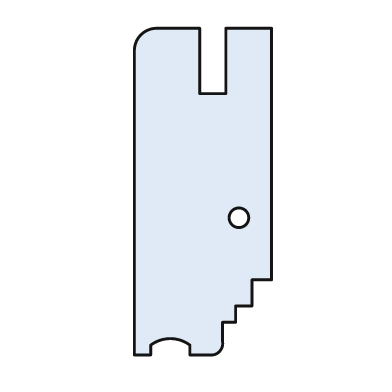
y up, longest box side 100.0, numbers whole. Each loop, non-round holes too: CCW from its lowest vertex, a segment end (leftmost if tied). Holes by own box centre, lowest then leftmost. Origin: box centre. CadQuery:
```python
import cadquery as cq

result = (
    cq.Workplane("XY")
    .moveTo(-21.0, -50.0)
    .lineTo(-16.0, -50.0)
    .lineTo(-16.0, -47.0)
    .threePointArc((-10.0, -45.0), (-4.0, -47.0))
    .lineTo(-4.0, -50.0)
    .lineTo(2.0, -50.0)
    .threePointArc((5.0, -49.0), (6.0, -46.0))
    .lineTo(6.0, -40.0)
    .lineTo(10.0, -40.0)
    .lineTo(10.0, -35.0)
    .lineTo(15.0, -35.0)
    .lineTo(15.0, -27.0)
    .lineTo(21.0, -27.0)
    .lineTo(21.0, 50.0)
    .lineTo(7.0, 50.0)
    .lineTo(7.0, 30.0)
    .lineTo(-1.0, 30.0)
    .lineTo(-1.0, 50.0)
    .lineTo(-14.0, 50.0)
    .threePointArc((-19.0, 48.0), (-21.0, 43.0))
    .close()
    .moveTo(11.0, -8.0)
    .circle(3.0)
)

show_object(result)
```